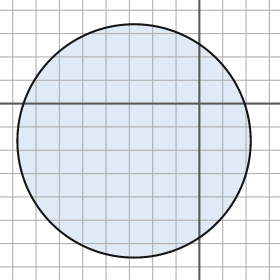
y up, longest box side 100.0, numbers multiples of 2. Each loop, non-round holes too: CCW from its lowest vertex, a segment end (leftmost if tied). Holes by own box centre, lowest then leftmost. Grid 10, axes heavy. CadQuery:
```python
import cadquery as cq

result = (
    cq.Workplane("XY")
    .moveTo(-28.0, -16.0)
    .circle(50.0)
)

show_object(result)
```